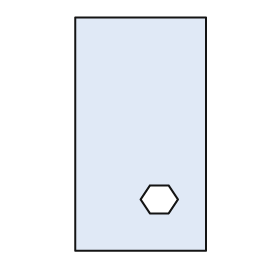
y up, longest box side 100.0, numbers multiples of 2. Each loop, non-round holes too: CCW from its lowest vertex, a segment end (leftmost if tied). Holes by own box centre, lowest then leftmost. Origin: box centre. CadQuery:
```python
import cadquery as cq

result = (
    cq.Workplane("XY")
    .moveTo(-28.0, -50.0)
    .lineTo(28.0, -50.0)
    .lineTo(28.0, 50.0)
    .lineTo(-28.0, 50.0)
    .close()
    .moveTo(4.0, -34.0)
    .lineTo(12.0, -34.0)
    .lineTo(16.0, -28.0)
    .lineTo(12.0, -22.0)
    .lineTo(4.0, -22.0)
    .lineTo(0.0, -28.0)
    .close()
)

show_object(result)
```